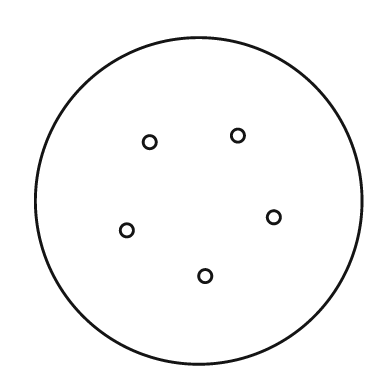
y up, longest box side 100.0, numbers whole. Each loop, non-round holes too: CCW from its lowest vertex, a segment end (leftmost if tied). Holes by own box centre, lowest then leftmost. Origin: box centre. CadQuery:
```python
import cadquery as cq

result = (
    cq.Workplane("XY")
    .moveTo(0.0, 0.0)
    .circle(50.0)
    .moveTo(2.0, -23.0)
    .circle(2.0)
    .moveTo(-22.0, -9.0)
    .circle(2.0)
    .moveTo(23.0, -5.0)
    .circle(2.0)
    .moveTo(-15.0, 18.0)
    .circle(2.0)
    .moveTo(12.0, 20.0)
    .circle(2.0)
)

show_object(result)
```